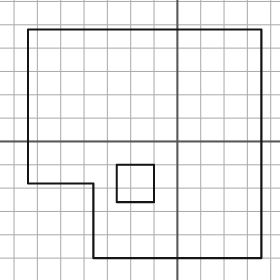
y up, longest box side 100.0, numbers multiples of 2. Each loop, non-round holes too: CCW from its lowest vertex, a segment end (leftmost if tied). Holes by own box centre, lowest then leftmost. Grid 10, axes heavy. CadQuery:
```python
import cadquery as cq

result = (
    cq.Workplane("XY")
    .moveTo(-36.0, -50.0)
    .lineTo(36.0, -50.0)
    .lineTo(36.0, 48.0)
    .lineTo(-64.0, 48.0)
    .lineTo(-64.0, -18.0)
    .lineTo(-36.0, -18.0)
    .close()
    .moveTo(-26.0, -26.0)
    .lineTo(-10.0, -26.0)
    .lineTo(-10.0, -10.0)
    .lineTo(-26.0, -10.0)
    .close()
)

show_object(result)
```